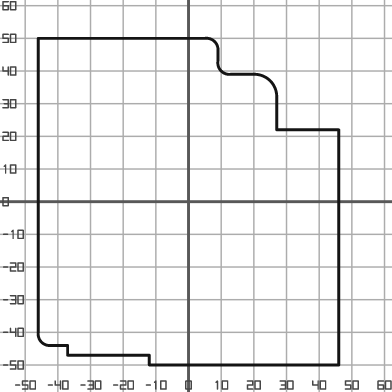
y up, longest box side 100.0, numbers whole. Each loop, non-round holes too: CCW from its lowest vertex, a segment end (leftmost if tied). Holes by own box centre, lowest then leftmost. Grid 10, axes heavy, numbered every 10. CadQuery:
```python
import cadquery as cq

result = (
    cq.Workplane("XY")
    .moveTo(-12.0, -50.0)
    .lineTo(46.0, -50.0)
    .lineTo(46.0, 22.0)
    .lineTo(27.0, 22.0)
    .lineTo(27.0, 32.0)
    .threePointArc((25.0, 37.0), (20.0, 39.0))
    .lineTo(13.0, 39.0)
    .threePointArc((10.0, 40.0), (9.0, 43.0))
    .lineTo(9.0, 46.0)
    .threePointArc((8.0, 49.0), (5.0, 50.0))
    .lineTo(-46.0, 50.0)
    .lineTo(-46.0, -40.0)
    .threePointArc((-45.0, -43.0), (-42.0, -44.0))
    .lineTo(-37.0, -44.0)
    .lineTo(-37.0, -47.0)
    .lineTo(-12.0, -47.0)
    .close()
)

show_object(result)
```